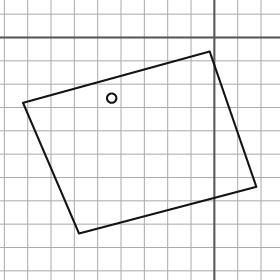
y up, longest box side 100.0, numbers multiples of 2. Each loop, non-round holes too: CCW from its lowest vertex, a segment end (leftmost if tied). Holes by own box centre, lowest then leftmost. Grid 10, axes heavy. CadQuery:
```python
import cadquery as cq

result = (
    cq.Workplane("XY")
    .moveTo(-58.0, -84.0)
    .lineTo(18.0, -64.0)
    .lineTo(-2.0, -6.0)
    .lineTo(-82.0, -28.0)
    .close()
    .moveTo(-44.0, -26.0)
    .circle(2.0)
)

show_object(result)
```